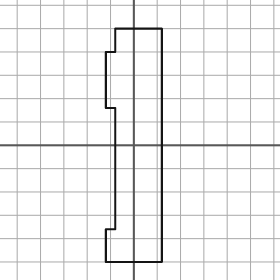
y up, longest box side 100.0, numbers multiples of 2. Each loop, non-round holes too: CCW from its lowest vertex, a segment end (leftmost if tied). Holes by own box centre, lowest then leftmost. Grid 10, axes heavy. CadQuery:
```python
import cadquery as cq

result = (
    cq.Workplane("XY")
    .moveTo(-12.0, -50.0)
    .lineTo(12.0, -50.0)
    .lineTo(12.0, 50.0)
    .lineTo(-8.0, 50.0)
    .lineTo(-8.0, 40.0)
    .lineTo(-12.0, 40.0)
    .lineTo(-12.0, 16.0)
    .lineTo(-8.0, 16.0)
    .lineTo(-8.0, -36.0)
    .lineTo(-12.0, -36.0)
    .close()
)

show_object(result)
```